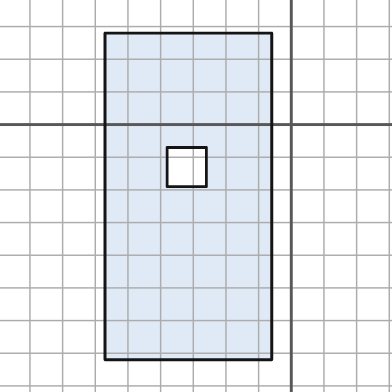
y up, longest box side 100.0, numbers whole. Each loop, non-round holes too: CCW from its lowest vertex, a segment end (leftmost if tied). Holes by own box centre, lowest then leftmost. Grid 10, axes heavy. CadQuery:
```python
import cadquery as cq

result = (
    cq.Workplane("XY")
    .moveTo(-57.0, -72.0)
    .lineTo(-6.0, -72.0)
    .lineTo(-6.0, 28.0)
    .lineTo(-57.0, 28.0)
    .close()
    .moveTo(-38.0, -19.0)
    .lineTo(-26.0, -19.0)
    .lineTo(-26.0, -7.0)
    .lineTo(-38.0, -7.0)
    .close()
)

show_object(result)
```